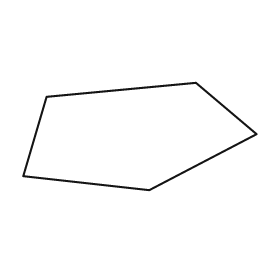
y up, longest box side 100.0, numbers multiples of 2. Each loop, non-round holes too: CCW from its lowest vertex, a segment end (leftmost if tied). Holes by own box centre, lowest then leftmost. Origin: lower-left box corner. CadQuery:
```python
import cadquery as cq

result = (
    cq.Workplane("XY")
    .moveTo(54.0, 0.0)
    .lineTo(100.0, 24.0)
    .lineTo(74.0, 46.0)
    .lineTo(10.0, 40.0)
    .lineTo(0.0, 6.0)
    .close()
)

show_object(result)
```